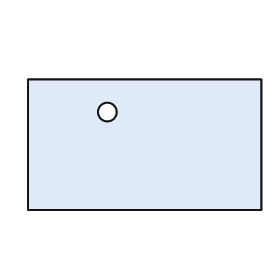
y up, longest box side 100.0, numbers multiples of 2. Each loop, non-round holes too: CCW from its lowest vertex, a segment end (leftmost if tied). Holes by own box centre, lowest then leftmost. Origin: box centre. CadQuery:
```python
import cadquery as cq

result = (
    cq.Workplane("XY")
    .moveTo(-50.0, -28.0)
    .lineTo(50.0, -28.0)
    .lineTo(50.0, 28.0)
    .lineTo(-50.0, 28.0)
    .close()
    .moveTo(-16.0, 14.0)
    .circle(4.0)
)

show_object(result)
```